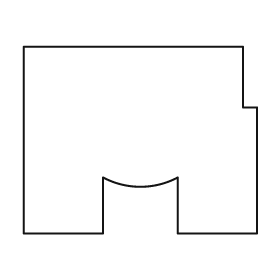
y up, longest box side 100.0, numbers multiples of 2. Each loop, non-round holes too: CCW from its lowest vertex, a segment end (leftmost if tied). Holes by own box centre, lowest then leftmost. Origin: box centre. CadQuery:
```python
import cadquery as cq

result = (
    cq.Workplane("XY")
    .moveTo(-50.0, -40.0)
    .lineTo(-16.0, -40.0)
    .lineTo(-16.0, -16.0)
    .threePointArc((0.0, -20.0), (16.0, -16.0))
    .lineTo(16.0, -40.0)
    .lineTo(50.0, -40.0)
    .lineTo(50.0, 14.0)
    .lineTo(44.0, 14.0)
    .lineTo(44.0, 40.0)
    .lineTo(-50.0, 40.0)
    .close()
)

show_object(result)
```